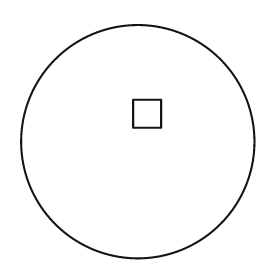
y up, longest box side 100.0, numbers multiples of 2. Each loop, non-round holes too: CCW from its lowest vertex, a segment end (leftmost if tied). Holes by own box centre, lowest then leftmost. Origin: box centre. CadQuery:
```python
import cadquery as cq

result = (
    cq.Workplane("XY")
    .moveTo(0.0, 0.0)
    .circle(50.0)
    .moveTo(-2.0, 6.0)
    .lineTo(10.0, 6.0)
    .lineTo(10.0, 18.0)
    .lineTo(-2.0, 18.0)
    .close()
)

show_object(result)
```